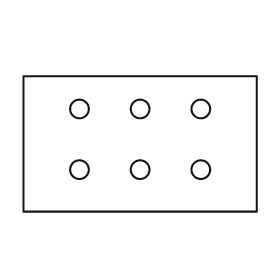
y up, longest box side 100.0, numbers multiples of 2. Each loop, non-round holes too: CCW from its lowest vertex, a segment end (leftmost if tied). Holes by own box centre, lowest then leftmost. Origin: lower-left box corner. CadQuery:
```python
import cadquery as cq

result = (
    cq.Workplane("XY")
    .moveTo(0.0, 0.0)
    .lineTo(100.0, 0.0)
    .lineTo(100.0, 58.0)
    .lineTo(0.0, 58.0)
    .close()
    .moveTo(24.0, 18.0)
    .circle(4.0)
    .moveTo(50.0, 18.0)
    .circle(4.0)
    .moveTo(76.0, 18.0)
    .circle(4.0)
    .moveTo(24.0, 44.0)
    .circle(4.0)
    .moveTo(50.0, 44.0)
    .circle(4.0)
    .moveTo(76.0, 44.0)
    .circle(4.0)
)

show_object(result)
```